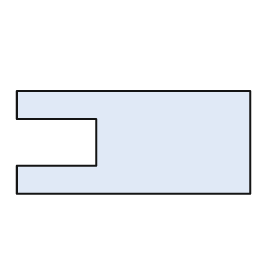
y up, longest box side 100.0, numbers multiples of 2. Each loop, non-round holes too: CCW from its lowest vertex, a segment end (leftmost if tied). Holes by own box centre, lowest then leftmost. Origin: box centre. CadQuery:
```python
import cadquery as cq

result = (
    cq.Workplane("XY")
    .moveTo(-50.0, -22.0)
    .lineTo(50.0, -22.0)
    .lineTo(50.0, 22.0)
    .lineTo(-50.0, 22.0)
    .lineTo(-50.0, 10.0)
    .lineTo(-16.0, 10.0)
    .lineTo(-16.0, -10.0)
    .lineTo(-50.0, -10.0)
    .close()
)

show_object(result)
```